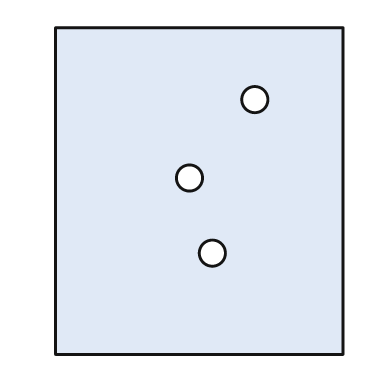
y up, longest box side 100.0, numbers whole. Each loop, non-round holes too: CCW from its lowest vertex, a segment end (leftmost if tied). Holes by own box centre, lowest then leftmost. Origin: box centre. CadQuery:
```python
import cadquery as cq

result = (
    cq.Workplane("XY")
    .moveTo(-44.0, -50.0)
    .lineTo(44.0, -50.0)
    .lineTo(44.0, 50.0)
    .lineTo(-44.0, 50.0)
    .close()
    .moveTo(4.0, -19.0)
    .circle(4.0)
    .moveTo(-3.0, 4.0)
    .circle(4.0)
    .moveTo(17.0, 28.0)
    .circle(4.0)
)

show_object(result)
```